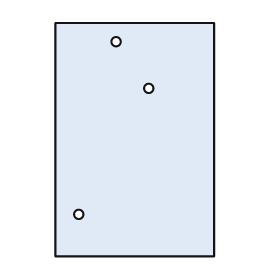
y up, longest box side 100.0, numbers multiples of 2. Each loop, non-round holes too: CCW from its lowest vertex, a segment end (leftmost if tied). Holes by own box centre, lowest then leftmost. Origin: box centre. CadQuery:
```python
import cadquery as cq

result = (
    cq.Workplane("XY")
    .moveTo(-34.0, -50.0)
    .lineTo(34.0, -50.0)
    .lineTo(34.0, 50.0)
    .lineTo(-34.0, 50.0)
    .close()
    .moveTo(-24.0, -32.0)
    .circle(2.0)
    .moveTo(6.0, 22.0)
    .circle(2.0)
    .moveTo(-8.0, 42.0)
    .circle(2.0)
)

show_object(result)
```